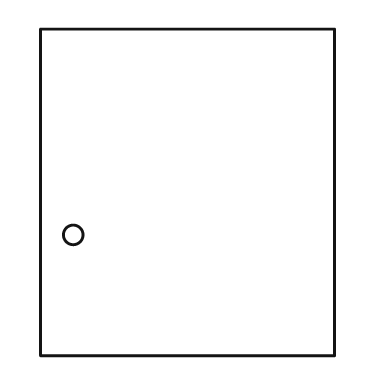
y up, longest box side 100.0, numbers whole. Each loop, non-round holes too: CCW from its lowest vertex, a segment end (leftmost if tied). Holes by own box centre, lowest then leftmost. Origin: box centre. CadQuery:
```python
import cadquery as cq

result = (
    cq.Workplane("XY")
    .moveTo(-45.0, -50.0)
    .lineTo(45.0, -50.0)
    .lineTo(45.0, 50.0)
    .lineTo(-45.0, 50.0)
    .close()
    .moveTo(-35.0, -13.0)
    .circle(3.0)
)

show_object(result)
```